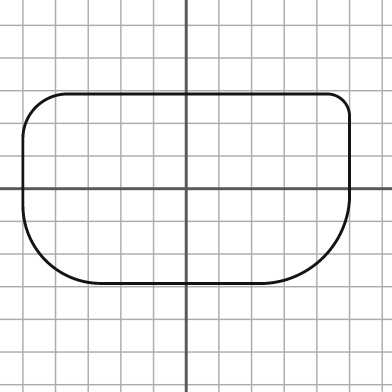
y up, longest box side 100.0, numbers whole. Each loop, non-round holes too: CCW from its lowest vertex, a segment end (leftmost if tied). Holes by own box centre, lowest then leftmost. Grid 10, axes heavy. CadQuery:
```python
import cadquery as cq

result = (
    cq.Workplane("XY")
    .moveTo(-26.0, -29.0)
    .lineTo(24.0, -29.0)
    .threePointArc((42.0, -21.0), (50.0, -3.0))
    .lineTo(50.0, 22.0)
    .threePointArc((48.0, 27.0), (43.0, 29.0))
    .lineTo(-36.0, 29.0)
    .threePointArc((-46.0, 25.0), (-50.0, 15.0))
    .lineTo(-50.0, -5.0)
    .threePointArc((-43.0, -22.0), (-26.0, -29.0))
    .close()
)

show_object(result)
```